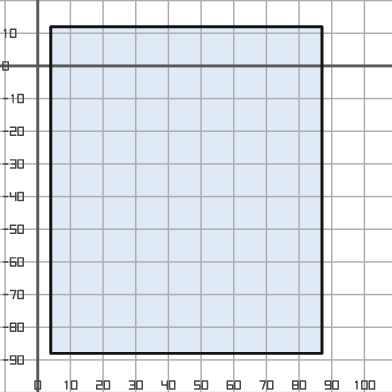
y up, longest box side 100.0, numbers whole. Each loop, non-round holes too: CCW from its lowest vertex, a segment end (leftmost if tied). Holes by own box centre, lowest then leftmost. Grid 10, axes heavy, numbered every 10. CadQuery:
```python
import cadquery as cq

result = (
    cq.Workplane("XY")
    .moveTo(4.0, -88.0)
    .lineTo(87.0, -88.0)
    .lineTo(87.0, 12.0)
    .lineTo(4.0, 12.0)
    .close()
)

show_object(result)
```